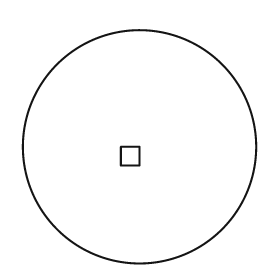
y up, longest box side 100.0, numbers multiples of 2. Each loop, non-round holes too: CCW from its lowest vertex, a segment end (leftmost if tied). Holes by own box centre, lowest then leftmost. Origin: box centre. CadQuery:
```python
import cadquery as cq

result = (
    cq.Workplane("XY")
    .moveTo(0.0, 0.0)
    .circle(50.0)
    .moveTo(-8.0, -8.0)
    .lineTo(0.0, -8.0)
    .lineTo(0.0, 0.0)
    .lineTo(-8.0, 0.0)
    .close()
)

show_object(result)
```